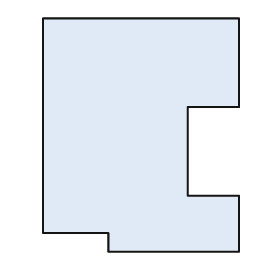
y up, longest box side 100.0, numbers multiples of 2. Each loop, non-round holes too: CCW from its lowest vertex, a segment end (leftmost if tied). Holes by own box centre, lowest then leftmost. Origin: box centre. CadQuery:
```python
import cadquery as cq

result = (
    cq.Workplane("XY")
    .moveTo(-14.0, -50.0)
    .lineTo(42.0, -50.0)
    .lineTo(42.0, -26.0)
    .lineTo(20.0, -26.0)
    .lineTo(20.0, 12.0)
    .lineTo(42.0, 12.0)
    .lineTo(42.0, 50.0)
    .lineTo(-42.0, 50.0)
    .lineTo(-42.0, -42.0)
    .lineTo(-14.0, -42.0)
    .close()
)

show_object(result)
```